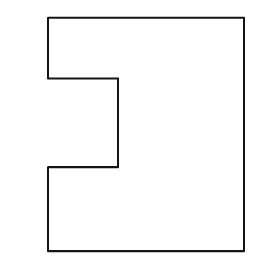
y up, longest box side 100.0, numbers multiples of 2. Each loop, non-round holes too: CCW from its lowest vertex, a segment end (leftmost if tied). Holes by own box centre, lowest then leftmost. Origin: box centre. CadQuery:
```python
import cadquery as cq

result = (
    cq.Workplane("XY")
    .moveTo(-42.0, -50.0)
    .lineTo(42.0, -50.0)
    .lineTo(42.0, 50.0)
    .lineTo(-42.0, 50.0)
    .lineTo(-42.0, 24.0)
    .lineTo(-12.0, 24.0)
    .lineTo(-12.0, -14.0)
    .lineTo(-42.0, -14.0)
    .close()
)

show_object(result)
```